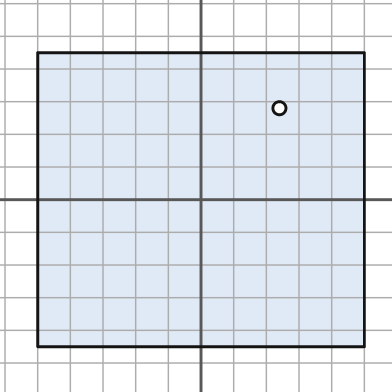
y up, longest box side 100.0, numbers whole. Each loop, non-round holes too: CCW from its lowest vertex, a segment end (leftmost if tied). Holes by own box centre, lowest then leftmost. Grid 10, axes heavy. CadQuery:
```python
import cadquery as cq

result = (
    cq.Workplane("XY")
    .moveTo(-50.0, -45.0)
    .lineTo(50.0, -45.0)
    .lineTo(50.0, 45.0)
    .lineTo(-50.0, 45.0)
    .close()
    .moveTo(24.0, 28.0)
    .circle(2.0)
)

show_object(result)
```